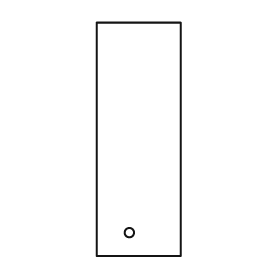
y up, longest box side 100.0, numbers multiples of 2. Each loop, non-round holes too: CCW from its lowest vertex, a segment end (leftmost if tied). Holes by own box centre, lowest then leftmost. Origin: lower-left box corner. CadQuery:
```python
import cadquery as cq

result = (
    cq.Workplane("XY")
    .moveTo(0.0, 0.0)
    .lineTo(36.0, 0.0)
    .lineTo(36.0, 100.0)
    .lineTo(0.0, 100.0)
    .close()
    .moveTo(14.0, 10.0)
    .circle(2.0)
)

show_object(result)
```